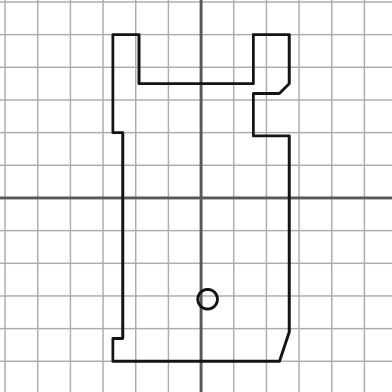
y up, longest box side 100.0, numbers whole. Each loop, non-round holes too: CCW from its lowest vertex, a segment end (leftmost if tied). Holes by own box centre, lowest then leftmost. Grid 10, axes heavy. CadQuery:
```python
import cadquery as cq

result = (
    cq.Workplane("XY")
    .moveTo(-27.0, -50.0)
    .lineTo(24.0, -50.0)
    .lineTo(27.0, -41.0)
    .lineTo(27.0, 19.0)
    .lineTo(16.0, 19.0)
    .lineTo(16.0, 32.0)
    .lineTo(24.0, 32.0)
    .lineTo(27.0, 35.0)
    .lineTo(27.0, 50.0)
    .lineTo(16.0, 50.0)
    .lineTo(16.0, 35.0)
    .lineTo(-19.0, 35.0)
    .lineTo(-19.0, 50.0)
    .lineTo(-27.0, 50.0)
    .lineTo(-27.0, 20.0)
    .lineTo(-24.0, 20.0)
    .lineTo(-24.0, -43.0)
    .lineTo(-27.0, -43.0)
    .close()
    .moveTo(2.0, -31.0)
    .circle(3.0)
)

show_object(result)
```